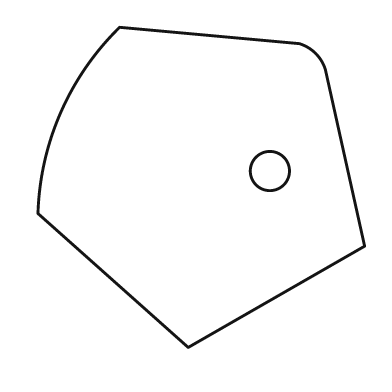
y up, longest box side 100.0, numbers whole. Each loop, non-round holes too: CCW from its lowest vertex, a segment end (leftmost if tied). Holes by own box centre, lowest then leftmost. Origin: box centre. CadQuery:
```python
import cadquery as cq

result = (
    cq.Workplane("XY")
    .moveTo(-4.0, -49.0)
    .lineTo(50.0, -18.0)
    .lineTo(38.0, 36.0)
    .threePointArc((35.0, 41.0), (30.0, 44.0))
    .lineTo(-25.0, 49.0)
    .threePointArc((-43.0, 23.0), (-50.0, -8.0))
    .close()
    .moveTo(21.0, 5.0)
    .circle(6.0)
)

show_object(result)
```